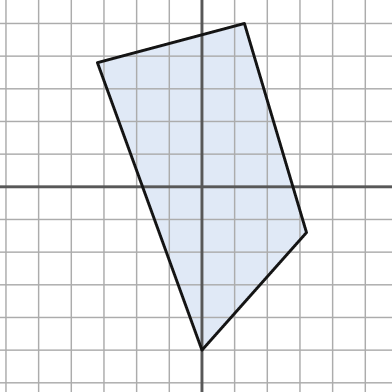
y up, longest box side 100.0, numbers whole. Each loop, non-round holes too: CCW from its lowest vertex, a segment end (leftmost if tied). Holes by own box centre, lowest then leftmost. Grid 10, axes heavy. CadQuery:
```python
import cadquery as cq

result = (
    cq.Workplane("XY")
    .moveTo(0.0, -50.0)
    .lineTo(32.0, -14.0)
    .lineTo(13.0, 50.0)
    .lineTo(-32.0, 38.0)
    .close()
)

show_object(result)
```